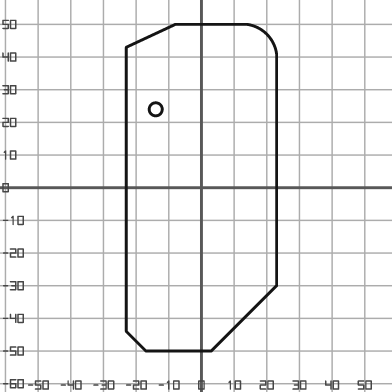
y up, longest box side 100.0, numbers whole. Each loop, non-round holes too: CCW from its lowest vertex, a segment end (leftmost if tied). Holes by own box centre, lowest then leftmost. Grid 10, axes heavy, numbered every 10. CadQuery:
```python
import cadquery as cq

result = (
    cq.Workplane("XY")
    .moveTo(-17.0, -50.0)
    .lineTo(3.0, -50.0)
    .lineTo(23.0, -30.0)
    .lineTo(23.0, 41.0)
    .threePointArc((20.0, 47.0), (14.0, 50.0))
    .lineTo(-8.0, 50.0)
    .lineTo(-23.0, 43.0)
    .lineTo(-23.0, -44.0)
    .close()
    .moveTo(-14.0, 24.0)
    .circle(2.0)
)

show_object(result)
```